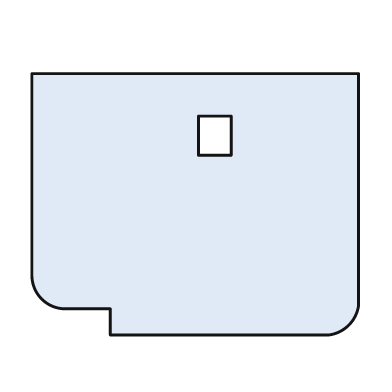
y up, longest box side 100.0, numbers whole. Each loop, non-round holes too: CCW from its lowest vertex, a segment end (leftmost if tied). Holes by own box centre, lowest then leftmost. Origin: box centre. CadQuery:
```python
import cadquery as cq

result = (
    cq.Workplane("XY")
    .moveTo(-26.0, -40.0)
    .lineTo(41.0, -40.0)
    .threePointArc((47.0, -37.0), (50.0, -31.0))
    .lineTo(50.0, 40.0)
    .lineTo(-50.0, 40.0)
    .lineTo(-50.0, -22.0)
    .threePointArc((-47.0, -29.0), (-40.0, -32.0))
    .lineTo(-26.0, -32.0)
    .close()
    .moveTo(1.0, 15.0)
    .lineTo(11.0, 15.0)
    .lineTo(11.0, 27.0)
    .lineTo(1.0, 27.0)
    .close()
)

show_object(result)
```